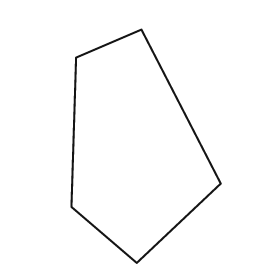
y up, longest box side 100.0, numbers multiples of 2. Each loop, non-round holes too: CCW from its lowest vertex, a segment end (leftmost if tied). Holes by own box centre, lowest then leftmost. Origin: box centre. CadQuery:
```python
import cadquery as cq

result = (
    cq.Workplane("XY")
    .moveTo(-4.0, -50.0)
    .lineTo(32.0, -16.0)
    .lineTo(-2.0, 50.0)
    .lineTo(-30.0, 38.0)
    .lineTo(-32.0, -26.0)
    .close()
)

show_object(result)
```